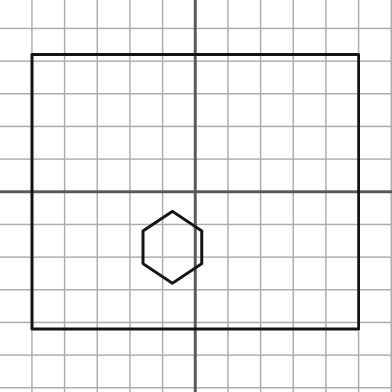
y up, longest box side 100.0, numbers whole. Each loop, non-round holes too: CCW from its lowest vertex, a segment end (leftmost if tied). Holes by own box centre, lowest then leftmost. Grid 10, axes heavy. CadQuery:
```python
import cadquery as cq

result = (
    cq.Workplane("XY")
    .moveTo(-50.0, -42.0)
    .lineTo(50.0, -42.0)
    .lineTo(50.0, 42.0)
    .lineTo(-50.0, 42.0)
    .close()
    .moveTo(-7.0, -28.0)
    .lineTo(2.0, -22.0)
    .lineTo(2.0, -12.0)
    .lineTo(-7.0, -6.0)
    .lineTo(-16.0, -12.0)
    .lineTo(-16.0, -22.0)
    .close()
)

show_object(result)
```